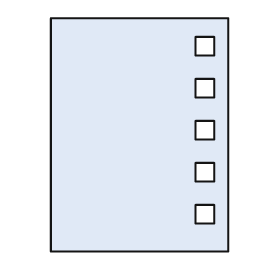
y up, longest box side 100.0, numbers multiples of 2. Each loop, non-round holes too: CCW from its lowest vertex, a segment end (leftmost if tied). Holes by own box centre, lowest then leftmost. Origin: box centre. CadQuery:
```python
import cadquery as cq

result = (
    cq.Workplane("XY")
    .moveTo(-38.0, -50.0)
    .lineTo(38.0, -50.0)
    .lineTo(38.0, 50.0)
    .lineTo(-38.0, 50.0)
    .close()
    .moveTo(24.0, -38.0)
    .lineTo(32.0, -38.0)
    .lineTo(32.0, -30.0)
    .lineTo(24.0, -30.0)
    .close()
    .moveTo(24.0, -20.0)
    .lineTo(32.0, -20.0)
    .lineTo(32.0, -12.0)
    .lineTo(24.0, -12.0)
    .close()
    .moveTo(24.0, -2.0)
    .lineTo(32.0, -2.0)
    .lineTo(32.0, 6.0)
    .lineTo(24.0, 6.0)
    .close()
    .moveTo(24.0, 16.0)
    .lineTo(32.0, 16.0)
    .lineTo(32.0, 24.0)
    .lineTo(24.0, 24.0)
    .close()
    .moveTo(24.0, 34.0)
    .lineTo(32.0, 34.0)
    .lineTo(32.0, 42.0)
    .lineTo(24.0, 42.0)
    .close()
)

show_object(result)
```